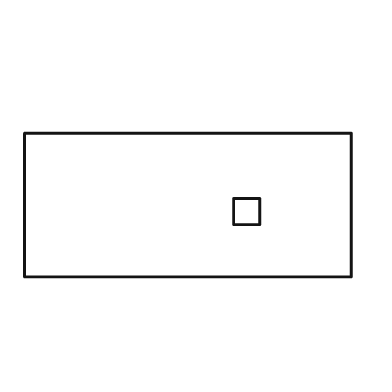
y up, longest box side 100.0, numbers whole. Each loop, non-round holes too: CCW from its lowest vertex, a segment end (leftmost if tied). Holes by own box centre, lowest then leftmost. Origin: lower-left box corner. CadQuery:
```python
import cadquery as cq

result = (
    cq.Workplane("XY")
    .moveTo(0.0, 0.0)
    .lineTo(100.0, 0.0)
    .lineTo(100.0, 44.0)
    .lineTo(0.0, 44.0)
    .close()
    .moveTo(64.0, 16.0)
    .lineTo(72.0, 16.0)
    .lineTo(72.0, 24.0)
    .lineTo(64.0, 24.0)
    .close()
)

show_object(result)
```